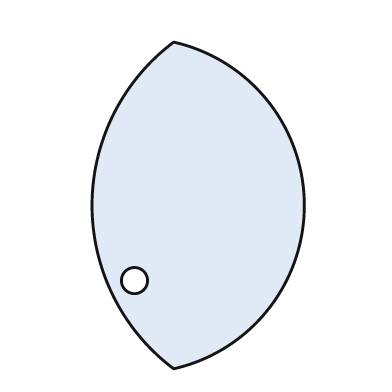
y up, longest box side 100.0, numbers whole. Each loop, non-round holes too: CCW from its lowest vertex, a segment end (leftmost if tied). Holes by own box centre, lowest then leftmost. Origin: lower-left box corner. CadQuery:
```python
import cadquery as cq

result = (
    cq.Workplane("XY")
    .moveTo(25.0, 0.0)
    .threePointArc((65.0, 50.0), (25.0, 100.0))
    .threePointArc((0.0, 50.0), (25.0, 0.0))
    .close()
    .moveTo(13.0, 27.0)
    .circle(4.0)
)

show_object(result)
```